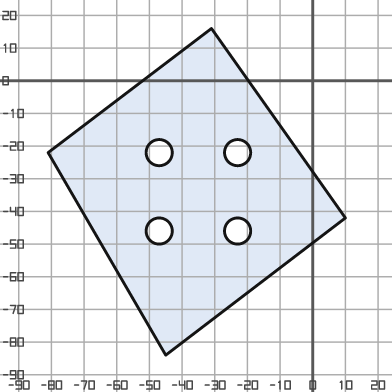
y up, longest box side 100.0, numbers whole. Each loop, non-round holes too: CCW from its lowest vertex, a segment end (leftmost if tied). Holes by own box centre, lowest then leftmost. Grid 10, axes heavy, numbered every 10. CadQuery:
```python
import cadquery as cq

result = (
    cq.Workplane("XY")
    .moveTo(-45.0, -84.0)
    .lineTo(10.0, -42.0)
    .lineTo(-31.0, 16.0)
    .lineTo(-81.0, -22.0)
    .close()
    .moveTo(-47.0, -46.0)
    .circle(4.0)
    .moveTo(-23.0, -46.0)
    .circle(4.0)
    .moveTo(-47.0, -22.0)
    .circle(4.0)
    .moveTo(-23.0, -22.0)
    .circle(4.0)
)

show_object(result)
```